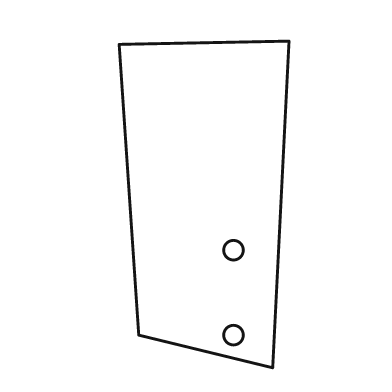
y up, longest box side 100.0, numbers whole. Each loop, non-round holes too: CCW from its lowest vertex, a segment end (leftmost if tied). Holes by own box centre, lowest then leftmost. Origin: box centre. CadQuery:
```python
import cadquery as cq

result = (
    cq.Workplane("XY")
    .moveTo(21.0, -50.0)
    .lineTo(26.0, 50.0)
    .lineTo(-26.0, 49.0)
    .lineTo(-20.0, -40.0)
    .close()
    .moveTo(9.0, -40.0)
    .circle(3.0)
    .moveTo(9.0, -14.0)
    .circle(3.0)
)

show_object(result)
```